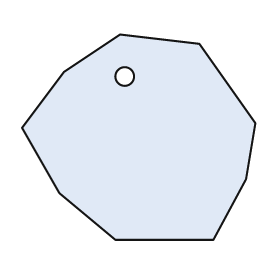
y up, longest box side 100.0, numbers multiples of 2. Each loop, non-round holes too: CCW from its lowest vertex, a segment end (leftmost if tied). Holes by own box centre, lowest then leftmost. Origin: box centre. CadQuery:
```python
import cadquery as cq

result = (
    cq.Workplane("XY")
    .moveTo(-10.0, -44.0)
    .lineTo(32.0, -44.0)
    .lineTo(46.0, -18.0)
    .lineTo(50.0, 6.0)
    .lineTo(26.0, 40.0)
    .lineTo(-8.0, 44.0)
    .lineTo(-32.0, 28.0)
    .lineTo(-50.0, 4.0)
    .lineTo(-34.0, -24.0)
    .close()
    .moveTo(-6.0, 26.0)
    .circle(4.0)
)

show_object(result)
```